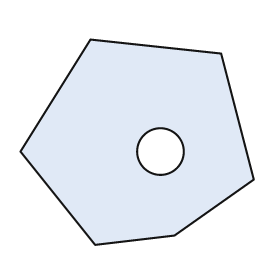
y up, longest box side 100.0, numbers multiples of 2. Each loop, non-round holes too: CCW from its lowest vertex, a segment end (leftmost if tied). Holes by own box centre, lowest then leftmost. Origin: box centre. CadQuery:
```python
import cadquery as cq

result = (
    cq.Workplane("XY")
    .moveTo(-18.0, -44.0)
    .lineTo(16.0, -40.0)
    .lineTo(50.0, -16.0)
    .lineTo(36.0, 38.0)
    .lineTo(-20.0, 44.0)
    .lineTo(-50.0, -4.0)
    .close()
    .moveTo(10.0, -4.0)
    .circle(10.0)
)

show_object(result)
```